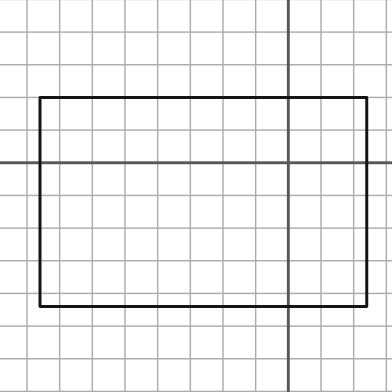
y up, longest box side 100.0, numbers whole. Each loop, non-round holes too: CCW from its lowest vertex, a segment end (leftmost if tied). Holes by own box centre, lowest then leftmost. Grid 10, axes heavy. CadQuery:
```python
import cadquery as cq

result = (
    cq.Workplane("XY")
    .moveTo(-76.0, -44.0)
    .lineTo(24.0, -44.0)
    .lineTo(24.0, 20.0)
    .lineTo(-76.0, 20.0)
    .close()
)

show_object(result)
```